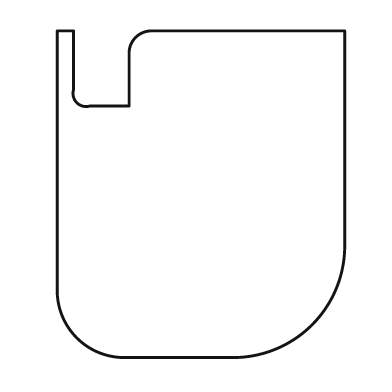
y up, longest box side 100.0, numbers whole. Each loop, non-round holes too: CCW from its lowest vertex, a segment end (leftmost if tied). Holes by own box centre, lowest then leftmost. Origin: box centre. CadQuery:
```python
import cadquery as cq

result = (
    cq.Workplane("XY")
    .moveTo(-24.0, -50.0)
    .lineTo(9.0, -50.0)
    .threePointArc((34.0, -40.0), (44.0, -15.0))
    .lineTo(44.0, 50.0)
    .lineTo(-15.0, 50.0)
    .threePointArc((-20.0, 48.0), (-22.0, 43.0))
    .lineTo(-22.0, 27.0)
    .lineTo(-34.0, 27.0)
    .threePointArc((-38.0, 28.0), (-39.0, 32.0))
    .lineTo(-39.0, 50.0)
    .lineTo(-44.0, 50.0)
    .lineTo(-44.0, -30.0)
    .threePointArc((-38.0, -44.0), (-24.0, -50.0))
    .close()
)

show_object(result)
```